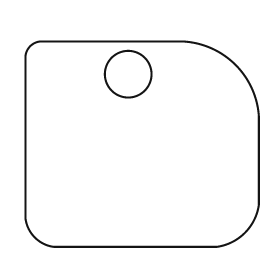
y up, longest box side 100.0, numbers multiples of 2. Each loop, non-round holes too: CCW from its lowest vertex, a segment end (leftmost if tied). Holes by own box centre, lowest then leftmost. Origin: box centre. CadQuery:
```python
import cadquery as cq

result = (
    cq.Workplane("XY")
    .moveTo(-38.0, -44.0)
    .lineTo(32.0, -44.0)
    .threePointArc((44.0, -38.0), (50.0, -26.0))
    .lineTo(50.0, 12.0)
    .threePointArc((40.0, 34.0), (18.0, 44.0))
    .lineTo(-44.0, 44.0)
    .threePointArc((-48.0, 42.0), (-50.0, 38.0))
    .lineTo(-50.0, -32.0)
    .threePointArc((-46.0, -40.0), (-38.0, -44.0))
    .close()
    .moveTo(-6.0, 30.0)
    .circle(10.0)
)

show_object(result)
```